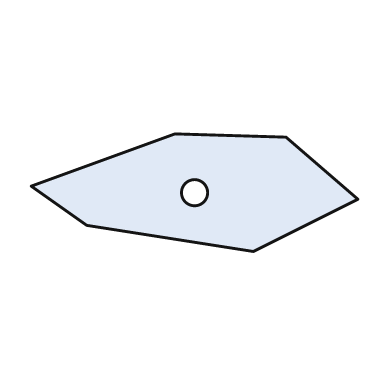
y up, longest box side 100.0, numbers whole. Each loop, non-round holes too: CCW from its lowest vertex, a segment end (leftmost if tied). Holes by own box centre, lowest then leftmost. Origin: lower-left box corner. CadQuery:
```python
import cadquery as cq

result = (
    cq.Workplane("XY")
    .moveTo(68.0, 0.0)
    .lineTo(100.0, 16.0)
    .lineTo(78.0, 35.0)
    .lineTo(44.0, 36.0)
    .lineTo(0.0, 20.0)
    .lineTo(17.0, 8.0)
    .close()
    .moveTo(50.0, 18.0)
    .circle(4.0)
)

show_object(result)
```